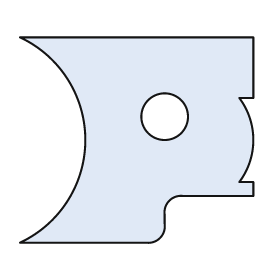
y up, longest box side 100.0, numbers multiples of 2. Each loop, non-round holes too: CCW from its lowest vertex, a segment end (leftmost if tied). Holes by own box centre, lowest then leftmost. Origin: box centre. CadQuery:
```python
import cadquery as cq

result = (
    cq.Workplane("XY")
    .moveTo(-50.0, -44.0)
    .lineTo(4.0, -44.0)
    .threePointArc((10.0, -42.0), (12.0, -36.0))
    .lineTo(12.0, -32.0)
    .threePointArc((14.0, -26.0), (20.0, -24.0))
    .lineTo(50.0, -24.0)
    .lineTo(50.0, -18.0)
    .lineTo(44.0, -18.0)
    .threePointArc((50.0, 0.0), (44.0, 18.0))
    .lineTo(50.0, 18.0)
    .lineTo(50.0, 44.0)
    .lineTo(-50.0, 44.0)
    .threePointArc((-22.0, 0.0), (-50.0, -44.0))
    .close()
    .moveTo(12.0, 10.0)
    .circle(10.0)
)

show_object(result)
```